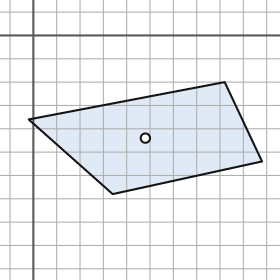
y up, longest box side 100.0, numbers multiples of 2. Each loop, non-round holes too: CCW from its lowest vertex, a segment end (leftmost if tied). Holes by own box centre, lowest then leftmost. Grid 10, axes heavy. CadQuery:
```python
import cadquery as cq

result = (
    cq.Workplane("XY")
    .moveTo(34.0, -68.0)
    .lineTo(98.0, -54.0)
    .lineTo(82.0, -20.0)
    .lineTo(-2.0, -36.0)
    .close()
    .moveTo(48.0, -44.0)
    .circle(2.0)
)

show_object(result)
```